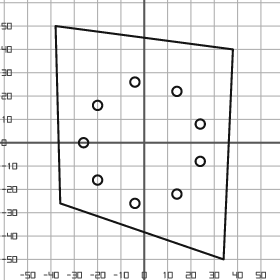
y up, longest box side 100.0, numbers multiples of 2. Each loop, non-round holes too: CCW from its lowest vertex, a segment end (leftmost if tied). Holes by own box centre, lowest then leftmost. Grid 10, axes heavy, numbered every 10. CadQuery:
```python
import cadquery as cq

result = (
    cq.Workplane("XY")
    .moveTo(34.0, -50.0)
    .lineTo(38.0, 40.0)
    .lineTo(-38.0, 50.0)
    .lineTo(-36.0, -26.0)
    .close()
    .moveTo(-4.0, -26.0)
    .circle(2.0)
    .moveTo(14.0, -22.0)
    .circle(2.0)
    .moveTo(-20.0, -16.0)
    .circle(2.0)
    .moveTo(24.0, -8.0)
    .circle(2.0)
    .moveTo(-26.0, 0.0)
    .circle(2.0)
    .moveTo(24.0, 8.0)
    .circle(2.0)
    .moveTo(-20.0, 16.0)
    .circle(2.0)
    .moveTo(14.0, 22.0)
    .circle(2.0)
    .moveTo(-4.0, 26.0)
    .circle(2.0)
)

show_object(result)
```